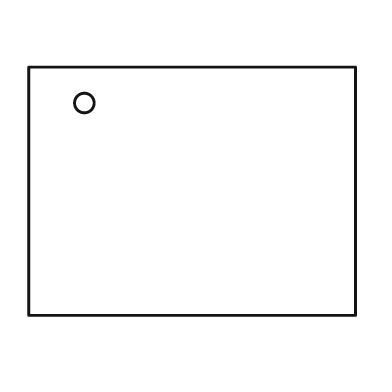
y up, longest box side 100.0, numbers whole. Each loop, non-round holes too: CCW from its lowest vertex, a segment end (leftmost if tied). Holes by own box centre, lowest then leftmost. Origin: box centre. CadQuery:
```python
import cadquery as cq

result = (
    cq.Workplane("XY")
    .moveTo(-50.0, -38.0)
    .lineTo(50.0, -38.0)
    .lineTo(50.0, 38.0)
    .lineTo(-50.0, 38.0)
    .close()
    .moveTo(-33.0, 27.0)
    .circle(3.0)
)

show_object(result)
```